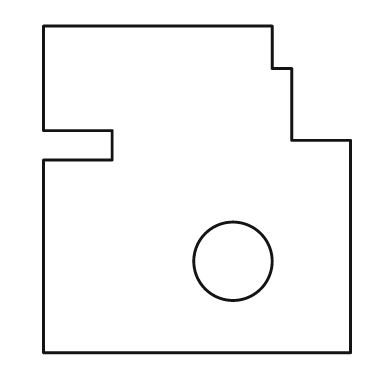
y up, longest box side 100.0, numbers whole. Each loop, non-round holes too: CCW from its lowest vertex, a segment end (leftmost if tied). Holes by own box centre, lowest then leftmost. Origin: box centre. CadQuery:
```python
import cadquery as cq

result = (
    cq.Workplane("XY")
    .moveTo(-47.0, -50.0)
    .lineTo(47.0, -50.0)
    .lineTo(47.0, 15.0)
    .lineTo(29.0, 15.0)
    .lineTo(29.0, 37.0)
    .lineTo(23.0, 37.0)
    .lineTo(23.0, 50.0)
    .lineTo(-47.0, 50.0)
    .lineTo(-47.0, 18.0)
    .lineTo(-26.0, 18.0)
    .lineTo(-26.0, 9.0)
    .lineTo(-47.0, 9.0)
    .close()
    .moveTo(11.0, -22.0)
    .circle(12.0)
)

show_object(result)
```